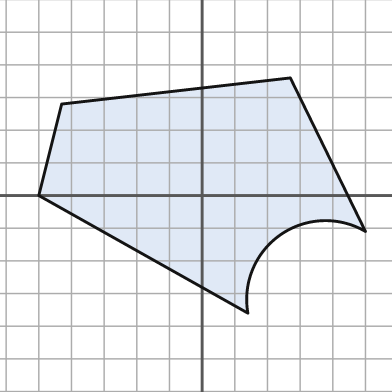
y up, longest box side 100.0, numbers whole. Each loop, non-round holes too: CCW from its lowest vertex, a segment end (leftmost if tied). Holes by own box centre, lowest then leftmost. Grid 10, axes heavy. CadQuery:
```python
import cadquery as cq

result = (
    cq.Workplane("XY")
    .moveTo(14.0, -36.0)
    .threePointArc((24.0, -12.0), (50.0, -11.0))
    .lineTo(27.0, 36.0)
    .lineTo(-43.0, 28.0)
    .lineTo(-50.0, 0.0)
    .close()
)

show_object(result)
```